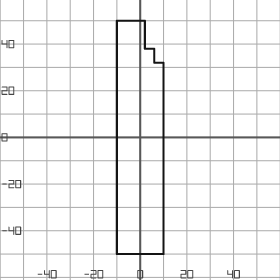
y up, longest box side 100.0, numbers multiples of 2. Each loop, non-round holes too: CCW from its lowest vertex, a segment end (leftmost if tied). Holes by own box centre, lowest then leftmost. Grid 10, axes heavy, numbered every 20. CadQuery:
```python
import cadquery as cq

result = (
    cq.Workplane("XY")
    .moveTo(-10.0, -50.0)
    .lineTo(10.0, -50.0)
    .lineTo(10.0, 32.0)
    .lineTo(6.0, 32.0)
    .lineTo(6.0, 38.0)
    .lineTo(2.0, 38.0)
    .lineTo(2.0, 50.0)
    .lineTo(-10.0, 50.0)
    .close()
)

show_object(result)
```